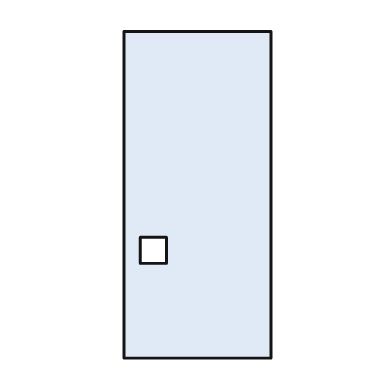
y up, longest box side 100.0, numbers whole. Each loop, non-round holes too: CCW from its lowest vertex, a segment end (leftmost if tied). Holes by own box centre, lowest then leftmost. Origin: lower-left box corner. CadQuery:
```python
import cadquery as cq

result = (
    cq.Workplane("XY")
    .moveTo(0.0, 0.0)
    .lineTo(45.0, 0.0)
    .lineTo(45.0, 100.0)
    .lineTo(0.0, 100.0)
    .close()
    .moveTo(5.0, 29.0)
    .lineTo(13.0, 29.0)
    .lineTo(13.0, 37.0)
    .lineTo(5.0, 37.0)
    .close()
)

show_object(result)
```